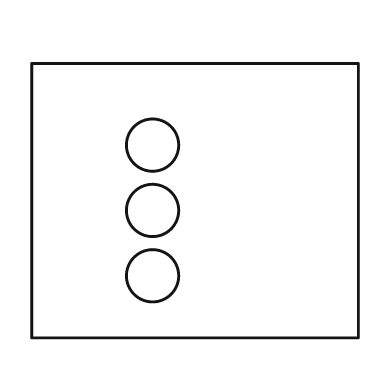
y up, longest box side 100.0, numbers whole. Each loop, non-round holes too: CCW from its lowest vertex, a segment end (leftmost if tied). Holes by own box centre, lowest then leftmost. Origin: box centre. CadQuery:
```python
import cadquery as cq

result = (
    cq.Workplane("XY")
    .moveTo(-50.0, -42.0)
    .lineTo(50.0, -42.0)
    .lineTo(50.0, 42.0)
    .lineTo(-50.0, 42.0)
    .close()
    .moveTo(-13.0, -23.0)
    .circle(8.0)
    .moveTo(-13.0, -3.0)
    .circle(8.0)
    .moveTo(-13.0, 17.0)
    .circle(8.0)
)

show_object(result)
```